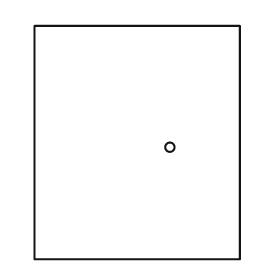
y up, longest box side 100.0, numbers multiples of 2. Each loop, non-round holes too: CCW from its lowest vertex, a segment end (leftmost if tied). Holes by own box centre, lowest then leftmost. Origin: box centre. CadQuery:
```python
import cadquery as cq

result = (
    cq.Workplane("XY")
    .moveTo(-44.0, -50.0)
    .lineTo(44.0, -50.0)
    .lineTo(44.0, 50.0)
    .lineTo(-44.0, 50.0)
    .close()
    .moveTo(14.0, -2.0)
    .circle(2.0)
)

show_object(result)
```